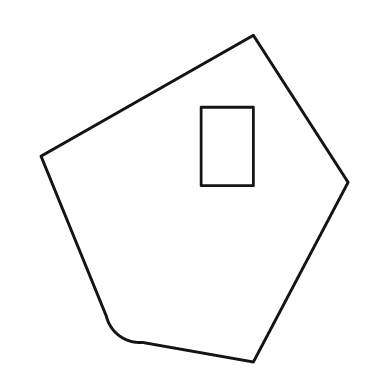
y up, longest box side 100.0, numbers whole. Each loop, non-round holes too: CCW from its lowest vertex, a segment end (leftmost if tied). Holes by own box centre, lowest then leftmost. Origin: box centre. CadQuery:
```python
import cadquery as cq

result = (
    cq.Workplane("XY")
    .moveTo(18.0, -50.0)
    .lineTo(47.0, 5.0)
    .lineTo(18.0, 50.0)
    .lineTo(-47.0, 13.0)
    .lineTo(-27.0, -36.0)
    .threePointArc((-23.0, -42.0), (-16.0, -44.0))
    .close()
    .moveTo(2.0, 4.0)
    .lineTo(18.0, 4.0)
    .lineTo(18.0, 28.0)
    .lineTo(2.0, 28.0)
    .close()
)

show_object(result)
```